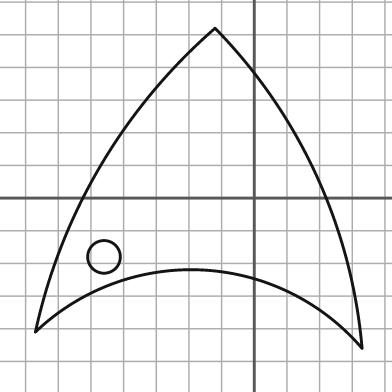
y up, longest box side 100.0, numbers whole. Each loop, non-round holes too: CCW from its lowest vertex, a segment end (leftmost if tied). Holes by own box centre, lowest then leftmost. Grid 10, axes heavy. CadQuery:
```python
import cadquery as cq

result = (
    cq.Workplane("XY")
    .moveTo(33.0, -46.0)
    .threePointArc((19.0, 7.0), (-12.0, 52.0))
    .threePointArc((-47.0, 10.0), (-67.0, -41.0))
    .threePointArc((-16.0, -22.0), (33.0, -46.0))
    .close()
    .moveTo(-46.0, -18.0)
    .circle(5.0)
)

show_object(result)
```